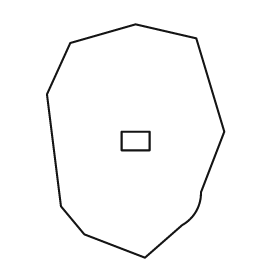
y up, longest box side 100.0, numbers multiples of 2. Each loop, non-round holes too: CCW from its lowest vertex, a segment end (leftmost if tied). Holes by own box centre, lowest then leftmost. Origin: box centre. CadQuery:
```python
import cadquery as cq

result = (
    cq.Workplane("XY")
    .moveTo(4.0, -50.0)
    .lineTo(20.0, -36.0)
    .threePointArc((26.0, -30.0), (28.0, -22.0))
    .lineTo(38.0, 4.0)
    .lineTo(26.0, 44.0)
    .lineTo(0.0, 50.0)
    .lineTo(-28.0, 42.0)
    .lineTo(-38.0, 20.0)
    .lineTo(-32.0, -28.0)
    .lineTo(-22.0, -40.0)
    .close()
    .moveTo(-6.0, -4.0)
    .lineTo(6.0, -4.0)
    .lineTo(6.0, 4.0)
    .lineTo(-6.0, 4.0)
    .close()
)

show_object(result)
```